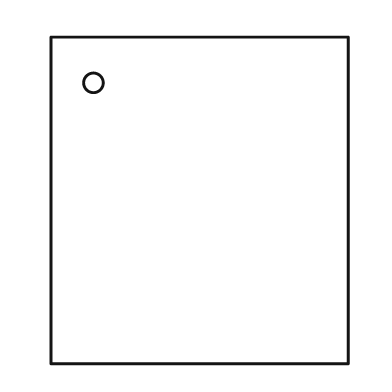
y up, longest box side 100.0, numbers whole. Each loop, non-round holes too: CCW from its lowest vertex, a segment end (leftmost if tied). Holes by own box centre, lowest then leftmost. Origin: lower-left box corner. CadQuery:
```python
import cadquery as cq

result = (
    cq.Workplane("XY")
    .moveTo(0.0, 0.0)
    .lineTo(91.0, 0.0)
    .lineTo(91.0, 100.0)
    .lineTo(0.0, 100.0)
    .close()
    .moveTo(13.0, 86.0)
    .circle(3.0)
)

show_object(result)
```